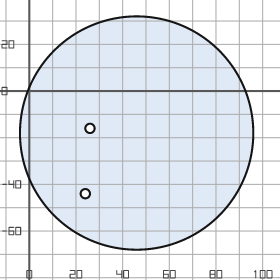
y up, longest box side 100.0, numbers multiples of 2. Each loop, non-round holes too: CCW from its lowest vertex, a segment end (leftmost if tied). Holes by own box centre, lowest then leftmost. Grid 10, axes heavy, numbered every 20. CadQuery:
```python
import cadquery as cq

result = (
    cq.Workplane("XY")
    .moveTo(46.0, -18.0)
    .circle(50.0)
    .moveTo(24.0, -44.0)
    .circle(2.0)
    .moveTo(26.0, -16.0)
    .circle(2.0)
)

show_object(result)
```